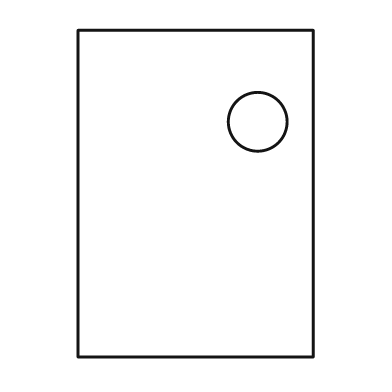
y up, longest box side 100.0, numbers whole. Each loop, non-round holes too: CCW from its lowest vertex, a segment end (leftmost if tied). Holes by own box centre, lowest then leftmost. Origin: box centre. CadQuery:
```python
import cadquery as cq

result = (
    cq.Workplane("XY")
    .moveTo(-36.0, -50.0)
    .lineTo(36.0, -50.0)
    .lineTo(36.0, 50.0)
    .lineTo(-36.0, 50.0)
    .close()
    .moveTo(19.0, 22.0)
    .circle(9.0)
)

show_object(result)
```